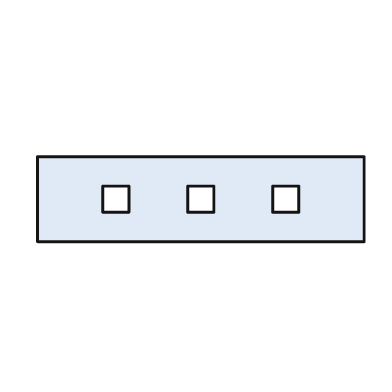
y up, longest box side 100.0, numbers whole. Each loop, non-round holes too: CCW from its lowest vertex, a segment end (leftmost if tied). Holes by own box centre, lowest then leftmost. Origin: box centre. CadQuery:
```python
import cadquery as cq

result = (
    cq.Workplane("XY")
    .moveTo(-50.0, -13.0)
    .lineTo(50.0, -13.0)
    .lineTo(50.0, 13.0)
    .lineTo(-50.0, 13.0)
    .close()
    .moveTo(-30.0, -4.0)
    .lineTo(-22.0, -4.0)
    .lineTo(-22.0, 4.0)
    .lineTo(-30.0, 4.0)
    .close()
    .moveTo(-4.0, -4.0)
    .lineTo(4.0, -4.0)
    .lineTo(4.0, 4.0)
    .lineTo(-4.0, 4.0)
    .close()
    .moveTo(22.0, -4.0)
    .lineTo(30.0, -4.0)
    .lineTo(30.0, 4.0)
    .lineTo(22.0, 4.0)
    .close()
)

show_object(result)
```